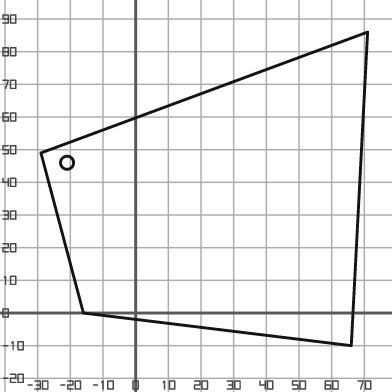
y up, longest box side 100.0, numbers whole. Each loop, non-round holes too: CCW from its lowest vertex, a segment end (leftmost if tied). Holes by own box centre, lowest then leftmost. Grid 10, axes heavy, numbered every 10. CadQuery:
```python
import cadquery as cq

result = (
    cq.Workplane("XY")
    .moveTo(66.0, -10.0)
    .lineTo(71.0, 86.0)
    .lineTo(-29.0, 49.0)
    .lineTo(-16.0, 0.0)
    .close()
    .moveTo(-21.0, 46.0)
    .circle(2.0)
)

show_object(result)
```